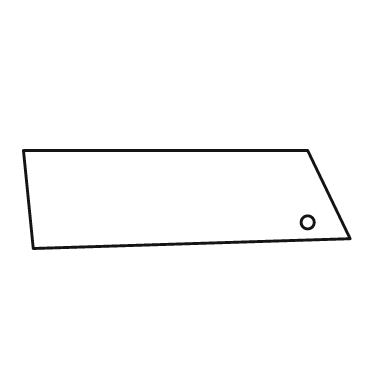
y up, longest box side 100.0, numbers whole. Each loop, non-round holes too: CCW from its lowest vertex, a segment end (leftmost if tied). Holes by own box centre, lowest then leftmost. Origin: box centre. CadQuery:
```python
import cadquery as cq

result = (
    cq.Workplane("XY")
    .moveTo(-47.0, -15.0)
    .lineTo(50.0, -12.0)
    .lineTo(37.0, 15.0)
    .lineTo(-50.0, 15.0)
    .close()
    .moveTo(37.0, -7.0)
    .circle(2.0)
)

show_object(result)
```